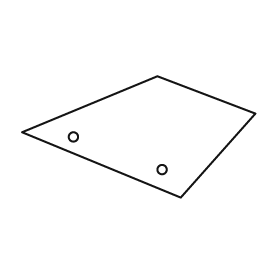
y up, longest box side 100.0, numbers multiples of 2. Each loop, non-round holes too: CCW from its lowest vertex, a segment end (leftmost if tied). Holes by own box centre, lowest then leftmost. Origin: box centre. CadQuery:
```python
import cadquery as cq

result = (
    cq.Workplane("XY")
    .moveTo(18.0, -26.0)
    .lineTo(50.0, 10.0)
    .lineTo(8.0, 26.0)
    .lineTo(-50.0, 2.0)
    .close()
    .moveTo(10.0, -14.0)
    .circle(2.0)
    .moveTo(-28.0, 0.0)
    .circle(2.0)
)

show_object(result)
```